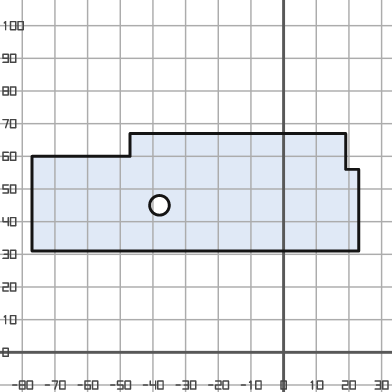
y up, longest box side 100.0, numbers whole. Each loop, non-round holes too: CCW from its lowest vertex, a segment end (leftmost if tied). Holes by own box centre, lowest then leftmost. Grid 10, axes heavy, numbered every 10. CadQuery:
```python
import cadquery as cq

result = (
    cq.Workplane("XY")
    .moveTo(-77.0, 31.0)
    .lineTo(23.0, 31.0)
    .lineTo(23.0, 56.0)
    .lineTo(19.0, 56.0)
    .lineTo(19.0, 67.0)
    .lineTo(-47.0, 67.0)
    .lineTo(-47.0, 60.0)
    .lineTo(-77.0, 60.0)
    .close()
    .moveTo(-38.0, 45.0)
    .circle(3.0)
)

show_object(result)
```